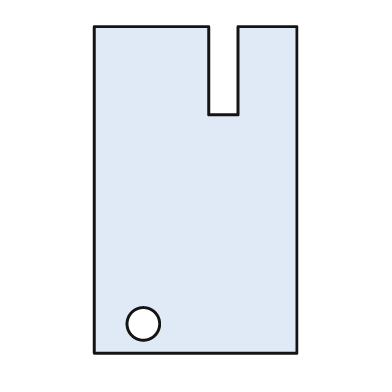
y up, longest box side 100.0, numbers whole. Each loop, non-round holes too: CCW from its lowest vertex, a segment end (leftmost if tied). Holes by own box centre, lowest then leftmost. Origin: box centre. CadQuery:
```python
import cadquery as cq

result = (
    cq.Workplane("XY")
    .moveTo(-31.0, -50.0)
    .lineTo(31.0, -50.0)
    .lineTo(31.0, 50.0)
    .lineTo(13.0, 50.0)
    .lineTo(13.0, 23.0)
    .lineTo(4.0, 23.0)
    .lineTo(4.0, 50.0)
    .lineTo(-31.0, 50.0)
    .close()
    .moveTo(-16.0, -41.0)
    .circle(5.0)
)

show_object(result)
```